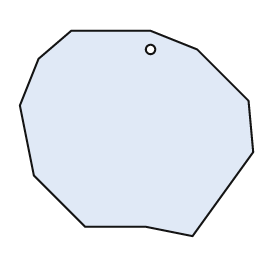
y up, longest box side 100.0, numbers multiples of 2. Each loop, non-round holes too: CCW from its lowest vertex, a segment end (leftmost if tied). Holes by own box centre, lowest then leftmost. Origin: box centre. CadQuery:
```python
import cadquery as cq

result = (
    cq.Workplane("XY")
    .moveTo(24.0, -44.0)
    .lineTo(50.0, -8.0)
    .lineTo(48.0, 14.0)
    .lineTo(26.0, 36.0)
    .lineTo(6.0, 44.0)
    .lineTo(-28.0, 44.0)
    .lineTo(-42.0, 32.0)
    .lineTo(-50.0, 12.0)
    .lineTo(-44.0, -18.0)
    .lineTo(-22.0, -40.0)
    .lineTo(4.0, -40.0)
    .close()
    .moveTo(6.0, 36.0)
    .circle(2.0)
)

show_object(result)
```